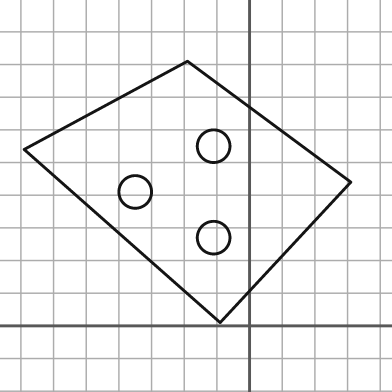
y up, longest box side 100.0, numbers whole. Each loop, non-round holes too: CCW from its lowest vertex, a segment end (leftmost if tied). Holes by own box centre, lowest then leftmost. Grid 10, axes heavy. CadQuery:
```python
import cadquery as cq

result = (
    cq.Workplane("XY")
    .moveTo(-9.0, 1.0)
    .lineTo(31.0, 44.0)
    .lineTo(-19.0, 81.0)
    .lineTo(-69.0, 54.0)
    .close()
    .moveTo(-11.0, 27.0)
    .circle(5.0)
    .moveTo(-35.0, 41.0)
    .circle(5.0)
    .moveTo(-11.0, 55.0)
    .circle(5.0)
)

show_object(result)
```